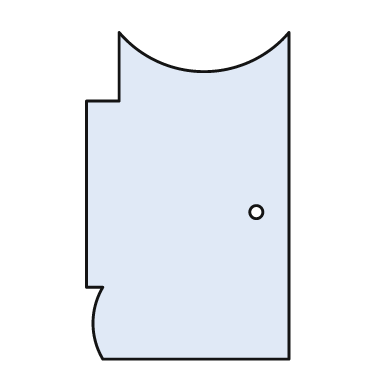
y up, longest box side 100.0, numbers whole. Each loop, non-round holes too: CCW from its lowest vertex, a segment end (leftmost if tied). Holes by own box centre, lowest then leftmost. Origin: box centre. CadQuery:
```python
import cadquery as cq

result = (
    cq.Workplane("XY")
    .moveTo(-26.0, -50.0)
    .lineTo(31.0, -50.0)
    .lineTo(31.0, 50.0)
    .threePointArc((5.0, 38.0), (-21.0, 50.0))
    .lineTo(-21.0, 29.0)
    .lineTo(-31.0, 29.0)
    .lineTo(-31.0, -28.0)
    .lineTo(-26.0, -28.0)
    .threePointArc((-29.0, -39.0), (-26.0, -50.0))
    .close()
    .moveTo(21.0, -5.0)
    .circle(2.0)
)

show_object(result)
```